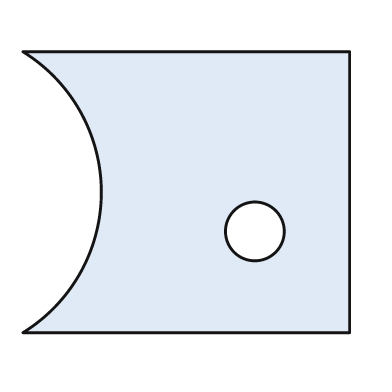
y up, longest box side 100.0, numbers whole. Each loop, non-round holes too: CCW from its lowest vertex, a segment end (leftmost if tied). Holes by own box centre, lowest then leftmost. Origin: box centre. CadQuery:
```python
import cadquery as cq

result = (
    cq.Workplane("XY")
    .moveTo(-50.0, -43.0)
    .lineTo(50.0, -43.0)
    .lineTo(50.0, 43.0)
    .lineTo(-50.0, 43.0)
    .threePointArc((-26.0, 0.0), (-50.0, -43.0))
    .close()
    .moveTo(21.0, -12.0)
    .circle(9.0)
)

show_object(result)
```